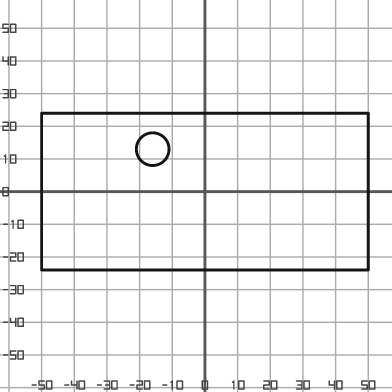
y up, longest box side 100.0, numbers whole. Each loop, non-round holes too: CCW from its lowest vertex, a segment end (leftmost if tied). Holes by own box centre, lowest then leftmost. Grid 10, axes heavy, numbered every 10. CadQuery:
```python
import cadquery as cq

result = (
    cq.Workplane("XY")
    .moveTo(-50.0, -24.0)
    .lineTo(50.0, -24.0)
    .lineTo(50.0, 24.0)
    .lineTo(-50.0, 24.0)
    .close()
    .moveTo(-16.0, 13.0)
    .circle(5.0)
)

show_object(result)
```